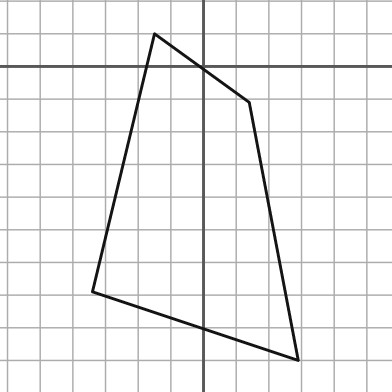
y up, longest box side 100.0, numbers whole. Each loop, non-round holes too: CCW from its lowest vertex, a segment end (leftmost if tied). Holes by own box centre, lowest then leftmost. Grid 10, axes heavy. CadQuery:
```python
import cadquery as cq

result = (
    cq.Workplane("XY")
    .moveTo(29.0, -90.0)
    .lineTo(14.0, -11.0)
    .lineTo(-15.0, 10.0)
    .lineTo(-34.0, -69.0)
    .close()
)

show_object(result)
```